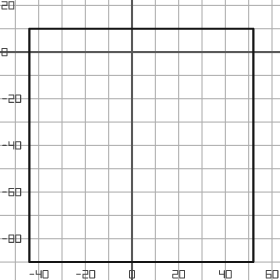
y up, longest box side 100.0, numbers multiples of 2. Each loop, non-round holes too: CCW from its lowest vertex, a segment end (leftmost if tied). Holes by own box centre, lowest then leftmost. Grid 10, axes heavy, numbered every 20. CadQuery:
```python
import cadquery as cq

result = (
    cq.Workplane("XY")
    .moveTo(-44.0, -90.0)
    .lineTo(52.0, -90.0)
    .lineTo(52.0, 10.0)
    .lineTo(-44.0, 10.0)
    .close()
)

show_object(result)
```